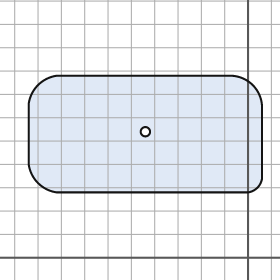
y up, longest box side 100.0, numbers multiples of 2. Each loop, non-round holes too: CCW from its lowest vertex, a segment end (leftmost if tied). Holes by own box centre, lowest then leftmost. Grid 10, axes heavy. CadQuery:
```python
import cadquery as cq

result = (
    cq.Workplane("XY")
    .moveTo(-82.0, 28.0)
    .lineTo(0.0, 28.0)
    .threePointArc((4.0, 30.0), (6.0, 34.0))
    .lineTo(6.0, 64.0)
    .threePointArc((2.0, 74.0), (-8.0, 78.0))
    .lineTo(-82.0, 78.0)
    .threePointArc((-90.0, 74.0), (-94.0, 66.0))
    .lineTo(-94.0, 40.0)
    .threePointArc((-90.0, 32.0), (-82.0, 28.0))
    .close()
    .moveTo(-44.0, 54.0)
    .circle(2.0)
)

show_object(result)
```